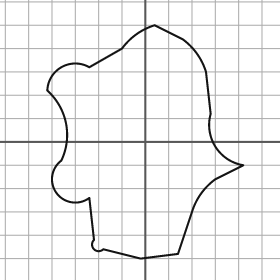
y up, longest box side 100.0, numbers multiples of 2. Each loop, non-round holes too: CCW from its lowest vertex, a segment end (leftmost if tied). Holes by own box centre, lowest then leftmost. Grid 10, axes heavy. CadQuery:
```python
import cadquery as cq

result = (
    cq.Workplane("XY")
    .moveTo(-2.0, -50.0)
    .lineTo(14.0, -48.0)
    .lineTo(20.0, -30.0)
    .threePointArc((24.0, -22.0), (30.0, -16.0))
    .lineTo(42.0, -10.0)
    .threePointArc((30.0, -2.0), (28.0, 12.0))
    .lineTo(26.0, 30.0)
    .threePointArc((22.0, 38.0), (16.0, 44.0))
    .lineTo(4.0, 50.0)
    .threePointArc((-4.0, 46.0), (-10.0, 40.0))
    .lineTo(-24.0, 32.0)
    .threePointArc((-36.0, 32.0), (-42.0, 22.0))
    .threePointArc((-34.0, 8.0), (-36.0, -8.0))
    .threePointArc((-38.0, -22.0), (-24.0, -24.0))
    .lineTo(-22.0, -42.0)
    .threePointArc((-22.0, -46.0), (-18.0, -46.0))
    .close()
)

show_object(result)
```